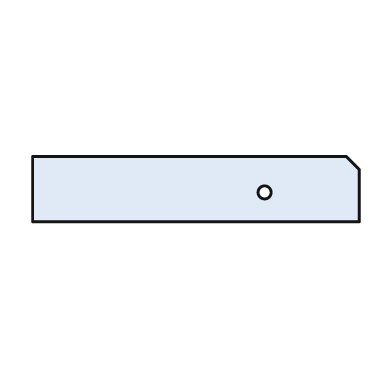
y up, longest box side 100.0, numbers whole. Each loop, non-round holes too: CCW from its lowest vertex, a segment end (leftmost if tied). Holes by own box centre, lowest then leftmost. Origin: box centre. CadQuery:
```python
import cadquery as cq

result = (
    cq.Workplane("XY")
    .moveTo(-50.0, -10.0)
    .lineTo(50.0, -10.0)
    .lineTo(50.0, 6.0)
    .lineTo(46.0, 10.0)
    .lineTo(-50.0, 10.0)
    .close()
    .moveTo(21.0, -1.0)
    .circle(2.0)
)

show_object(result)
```